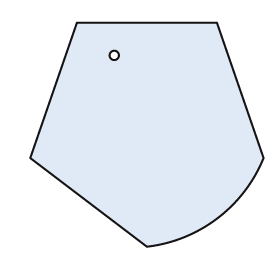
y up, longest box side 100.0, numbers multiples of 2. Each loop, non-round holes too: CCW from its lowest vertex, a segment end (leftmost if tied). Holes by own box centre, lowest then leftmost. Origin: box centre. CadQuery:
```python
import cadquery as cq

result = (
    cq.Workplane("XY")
    .moveTo(0.0, -48.0)
    .threePointArc((30.0, -36.0), (50.0, -10.0))
    .lineTo(30.0, 48.0)
    .lineTo(-30.0, 48.0)
    .lineTo(-50.0, -10.0)
    .close()
    .moveTo(-14.0, 34.0)
    .circle(2.0)
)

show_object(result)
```